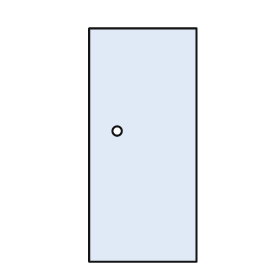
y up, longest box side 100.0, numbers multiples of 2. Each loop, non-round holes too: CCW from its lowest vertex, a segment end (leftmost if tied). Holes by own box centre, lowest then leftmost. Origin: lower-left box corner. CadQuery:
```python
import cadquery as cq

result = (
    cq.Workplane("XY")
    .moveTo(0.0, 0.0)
    .lineTo(46.0, 0.0)
    .lineTo(46.0, 100.0)
    .lineTo(0.0, 100.0)
    .close()
    .moveTo(12.0, 56.0)
    .circle(2.0)
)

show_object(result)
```